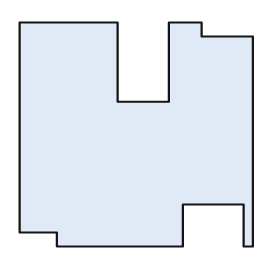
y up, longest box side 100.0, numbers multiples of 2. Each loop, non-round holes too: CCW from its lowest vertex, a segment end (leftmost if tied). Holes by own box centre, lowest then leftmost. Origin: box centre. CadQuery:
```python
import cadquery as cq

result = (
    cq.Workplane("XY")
    .moveTo(-34.0, -48.0)
    .lineTo(20.0, -48.0)
    .lineTo(20.0, -30.0)
    .lineTo(46.0, -30.0)
    .lineTo(46.0, -48.0)
    .lineTo(50.0, -48.0)
    .lineTo(50.0, 42.0)
    .lineTo(28.0, 42.0)
    .lineTo(28.0, 48.0)
    .lineTo(14.0, 48.0)
    .lineTo(14.0, 14.0)
    .lineTo(-8.0, 14.0)
    .lineTo(-8.0, 48.0)
    .lineTo(-50.0, 48.0)
    .lineTo(-50.0, -42.0)
    .lineTo(-34.0, -42.0)
    .close()
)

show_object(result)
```